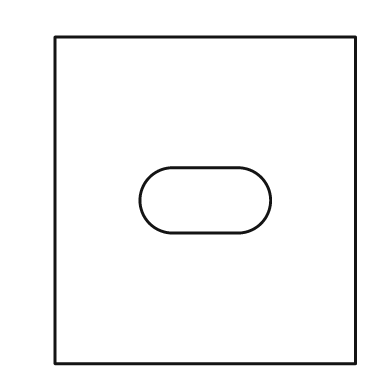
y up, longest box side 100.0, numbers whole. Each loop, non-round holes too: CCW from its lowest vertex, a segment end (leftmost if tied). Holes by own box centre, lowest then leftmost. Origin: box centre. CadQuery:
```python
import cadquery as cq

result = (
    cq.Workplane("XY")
    .moveTo(-46.0, -50.0)
    .lineTo(46.0, -50.0)
    .lineTo(46.0, 50.0)
    .lineTo(-46.0, 50.0)
    .close()
    .moveTo(-10.0, -10.0)
    .lineTo(10.0, -10.0)
    .threePointArc((20.0, 0.0), (10.0, 10.0))
    .lineTo(-10.0, 10.0)
    .threePointArc((-20.0, 0.0), (-10.0, -10.0))
    .close()
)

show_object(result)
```